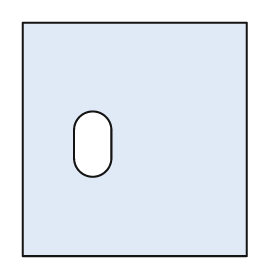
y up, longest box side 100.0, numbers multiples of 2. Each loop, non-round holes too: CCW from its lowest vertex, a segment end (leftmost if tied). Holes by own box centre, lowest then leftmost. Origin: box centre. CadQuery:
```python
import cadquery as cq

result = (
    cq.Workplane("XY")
    .moveTo(-48.0, -50.0)
    .lineTo(48.0, -50.0)
    .lineTo(48.0, 50.0)
    .lineTo(-48.0, 50.0)
    .close()
    .moveTo(-26.0, -8.0)
    .threePointArc((-18.0, -16.0), (-10.0, -8.0))
    .lineTo(-10.0, 4.0)
    .threePointArc((-18.0, 12.0), (-26.0, 4.0))
    .close()
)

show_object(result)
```